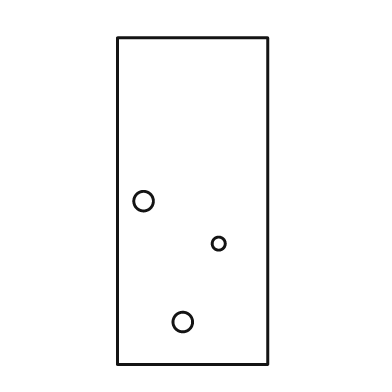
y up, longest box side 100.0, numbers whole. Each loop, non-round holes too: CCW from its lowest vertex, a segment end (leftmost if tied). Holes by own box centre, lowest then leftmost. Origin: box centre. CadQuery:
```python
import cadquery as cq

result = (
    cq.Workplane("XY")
    .moveTo(-23.0, -50.0)
    .lineTo(23.0, -50.0)
    .lineTo(23.0, 50.0)
    .lineTo(-23.0, 50.0)
    .close()
    .moveTo(-3.0, -37.0)
    .circle(3.0)
    .moveTo(8.0, -13.0)
    .circle(2.0)
    .moveTo(-15.0, 0.0)
    .circle(3.0)
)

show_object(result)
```